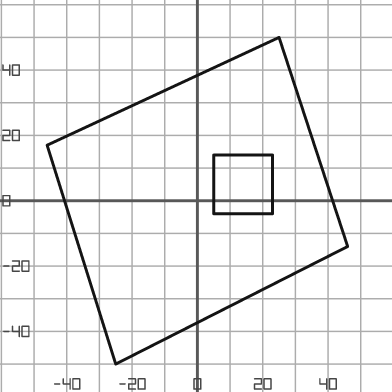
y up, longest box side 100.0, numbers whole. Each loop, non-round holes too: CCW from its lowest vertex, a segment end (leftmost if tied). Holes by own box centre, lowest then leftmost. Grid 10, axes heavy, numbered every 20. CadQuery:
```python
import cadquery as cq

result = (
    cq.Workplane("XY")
    .moveTo(-25.0, -50.0)
    .lineTo(46.0, -14.0)
    .lineTo(25.0, 50.0)
    .lineTo(-46.0, 17.0)
    .close()
    .moveTo(5.0, -4.0)
    .lineTo(23.0, -4.0)
    .lineTo(23.0, 14.0)
    .lineTo(5.0, 14.0)
    .close()
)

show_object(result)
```